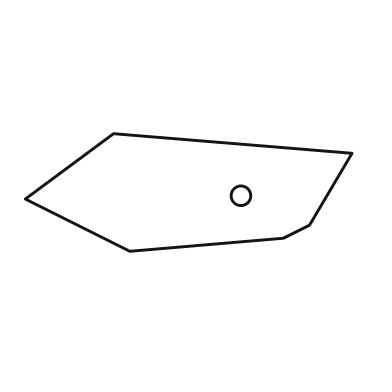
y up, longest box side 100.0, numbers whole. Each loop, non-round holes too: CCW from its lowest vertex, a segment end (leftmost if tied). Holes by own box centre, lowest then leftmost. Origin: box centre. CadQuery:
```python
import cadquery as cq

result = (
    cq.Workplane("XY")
    .moveTo(-18.0, -18.0)
    .lineTo(29.0, -14.0)
    .lineTo(37.0, -10.0)
    .lineTo(50.0, 12.0)
    .lineTo(-23.0, 18.0)
    .lineTo(-50.0, -2.0)
    .close()
    .moveTo(16.0, -1.0)
    .circle(3.0)
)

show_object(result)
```